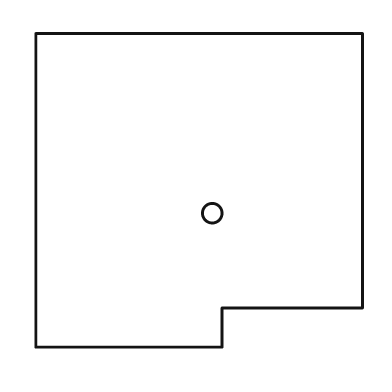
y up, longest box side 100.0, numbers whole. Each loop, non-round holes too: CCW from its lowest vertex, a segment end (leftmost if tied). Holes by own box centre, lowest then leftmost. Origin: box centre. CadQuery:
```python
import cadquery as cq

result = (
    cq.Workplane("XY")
    .moveTo(-50.0, -48.0)
    .lineTo(7.0, -48.0)
    .lineTo(7.0, -36.0)
    .lineTo(50.0, -36.0)
    .lineTo(50.0, 48.0)
    .lineTo(-50.0, 48.0)
    .close()
    .moveTo(4.0, -7.0)
    .circle(3.0)
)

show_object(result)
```